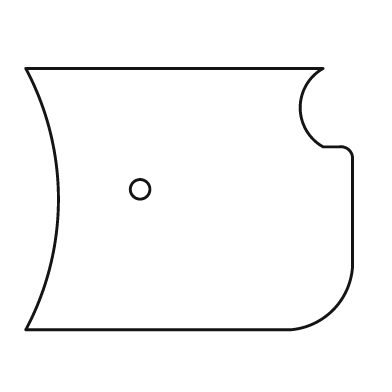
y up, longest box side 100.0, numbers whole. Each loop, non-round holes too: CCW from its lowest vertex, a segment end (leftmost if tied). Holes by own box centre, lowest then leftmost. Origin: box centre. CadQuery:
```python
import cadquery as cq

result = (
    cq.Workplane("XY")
    .moveTo(-50.0, -40.0)
    .lineTo(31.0, -40.0)
    .threePointArc((44.0, -34.0), (50.0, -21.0))
    .lineTo(50.0, 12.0)
    .threePointArc((49.0, 15.0), (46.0, 16.0))
    .lineTo(41.0, 16.0)
    .threePointArc((34.0, 28.0), (41.0, 40.0))
    .lineTo(-50.0, 40.0)
    .threePointArc((-40.0, 0.0), (-50.0, -40.0))
    .close()
    .moveTo(-15.0, 3.0)
    .circle(3.0)
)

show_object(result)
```